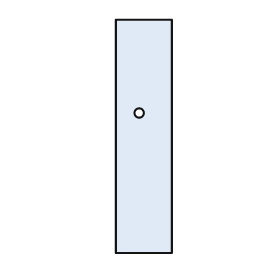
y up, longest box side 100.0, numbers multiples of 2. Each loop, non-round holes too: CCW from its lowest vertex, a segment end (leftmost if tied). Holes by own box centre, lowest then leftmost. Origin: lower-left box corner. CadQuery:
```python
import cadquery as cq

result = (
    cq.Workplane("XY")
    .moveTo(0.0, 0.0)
    .lineTo(24.0, 0.0)
    .lineTo(24.0, 100.0)
    .lineTo(0.0, 100.0)
    .close()
    .moveTo(10.0, 60.0)
    .circle(2.0)
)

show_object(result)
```